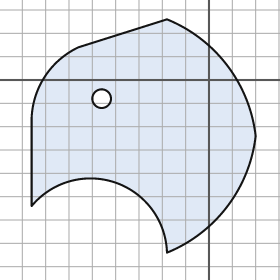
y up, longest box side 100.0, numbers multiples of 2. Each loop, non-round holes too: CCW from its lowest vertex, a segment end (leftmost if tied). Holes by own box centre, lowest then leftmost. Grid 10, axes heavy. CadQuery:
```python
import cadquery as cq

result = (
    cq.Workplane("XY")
    .moveTo(-18.0, -74.0)
    .threePointArc((8.0, -54.0), (20.0, -24.0))
    .threePointArc((8.0, 6.0), (-18.0, 26.0))
    .lineTo(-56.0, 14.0)
    .threePointArc((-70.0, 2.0), (-76.0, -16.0))
    .lineTo(-76.0, -54.0)
    .threePointArc((-40.0, -44.0), (-18.0, -74.0))
    .close()
    .moveTo(-46.0, -8.0)
    .circle(4.0)
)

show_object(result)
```